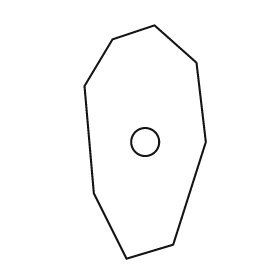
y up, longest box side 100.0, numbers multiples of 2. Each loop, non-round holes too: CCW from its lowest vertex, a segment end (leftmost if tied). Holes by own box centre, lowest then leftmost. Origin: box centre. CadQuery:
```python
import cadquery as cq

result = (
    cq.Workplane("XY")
    .moveTo(-8.0, -50.0)
    .lineTo(12.0, -44.0)
    .lineTo(26.0, 0.0)
    .lineTo(22.0, 34.0)
    .lineTo(4.0, 50.0)
    .lineTo(-14.0, 44.0)
    .lineTo(-26.0, 24.0)
    .lineTo(-22.0, -22.0)
    .close()
    .moveTo(0.0, 0.0)
    .circle(6.0)
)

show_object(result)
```